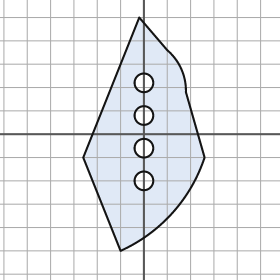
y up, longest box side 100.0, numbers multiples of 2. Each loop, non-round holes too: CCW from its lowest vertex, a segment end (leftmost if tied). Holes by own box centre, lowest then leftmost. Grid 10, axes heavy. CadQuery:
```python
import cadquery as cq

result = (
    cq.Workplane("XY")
    .moveTo(-10.0, -50.0)
    .threePointArc((12.0, -34.0), (26.0, -10.0))
    .lineTo(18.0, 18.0)
    .threePointArc((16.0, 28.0), (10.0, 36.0))
    .lineTo(-2.0, 50.0)
    .lineTo(-26.0, -10.0)
    .close()
    .moveTo(0.0, -20.0)
    .circle(4.0)
    .moveTo(0.0, -6.0)
    .circle(4.0)
    .moveTo(0.0, 8.0)
    .circle(4.0)
    .moveTo(0.0, 22.0)
    .circle(4.0)
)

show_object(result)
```